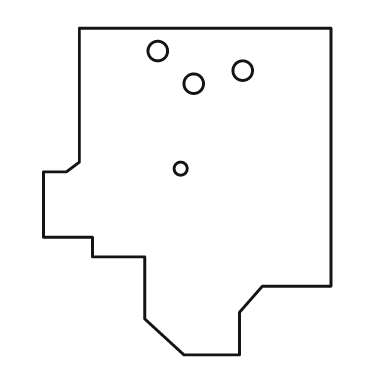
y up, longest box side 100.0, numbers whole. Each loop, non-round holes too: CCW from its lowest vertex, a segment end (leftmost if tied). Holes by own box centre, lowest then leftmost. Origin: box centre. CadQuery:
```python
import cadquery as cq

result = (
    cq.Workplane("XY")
    .moveTo(-1.0, -50.0)
    .lineTo(16.0, -50.0)
    .lineTo(16.0, -37.0)
    .lineTo(23.0, -29.0)
    .lineTo(44.0, -29.0)
    .lineTo(44.0, 50.0)
    .lineTo(-33.0, 50.0)
    .lineTo(-33.0, 9.0)
    .lineTo(-37.0, 6.0)
    .lineTo(-44.0, 6.0)
    .lineTo(-44.0, -14.0)
    .lineTo(-29.0, -14.0)
    .lineTo(-29.0, -20.0)
    .lineTo(-13.0, -20.0)
    .lineTo(-13.0, -39.0)
    .close()
    .moveTo(-2.0, 7.0)
    .circle(2.0)
    .moveTo(2.0, 33.0)
    .circle(3.0)
    .moveTo(17.0, 37.0)
    .circle(3.0)
    .moveTo(-9.0, 43.0)
    .circle(3.0)
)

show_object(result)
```